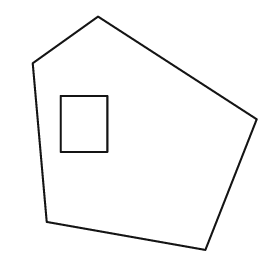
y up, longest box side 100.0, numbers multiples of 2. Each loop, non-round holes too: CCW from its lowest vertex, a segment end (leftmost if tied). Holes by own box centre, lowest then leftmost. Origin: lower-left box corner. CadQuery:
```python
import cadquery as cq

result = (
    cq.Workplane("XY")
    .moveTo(74.0, 0.0)
    .lineTo(96.0, 56.0)
    .lineTo(28.0, 100.0)
    .lineTo(0.0, 80.0)
    .lineTo(6.0, 12.0)
    .close()
    .moveTo(12.0, 42.0)
    .lineTo(32.0, 42.0)
    .lineTo(32.0, 66.0)
    .lineTo(12.0, 66.0)
    .close()
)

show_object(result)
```